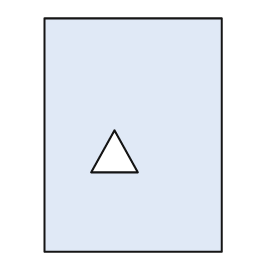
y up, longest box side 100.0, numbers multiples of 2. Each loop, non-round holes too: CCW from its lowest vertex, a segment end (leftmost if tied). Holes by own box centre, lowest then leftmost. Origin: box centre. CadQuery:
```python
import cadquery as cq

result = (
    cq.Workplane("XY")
    .moveTo(-38.0, -50.0)
    .lineTo(38.0, -50.0)
    .lineTo(38.0, 50.0)
    .lineTo(-38.0, 50.0)
    .close()
    .moveTo(-18.0, -16.0)
    .lineTo(2.0, -16.0)
    .lineTo(-8.0, 2.0)
    .close()
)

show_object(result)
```